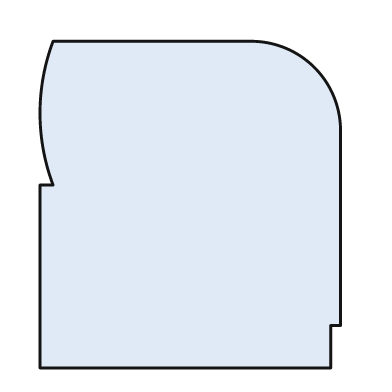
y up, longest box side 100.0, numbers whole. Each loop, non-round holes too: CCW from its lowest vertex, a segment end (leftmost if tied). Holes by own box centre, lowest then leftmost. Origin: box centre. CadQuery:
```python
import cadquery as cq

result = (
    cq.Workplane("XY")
    .moveTo(-46.0, -50.0)
    .lineTo(43.0, -50.0)
    .lineTo(43.0, -37.0)
    .lineTo(46.0, -37.0)
    .lineTo(46.0, 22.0)
    .threePointArc((38.0, 42.0), (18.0, 50.0))
    .lineTo(-42.0, 50.0)
    .threePointArc((-46.0, 28.0), (-42.0, 6.0))
    .lineTo(-46.0, 6.0)
    .close()
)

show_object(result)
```